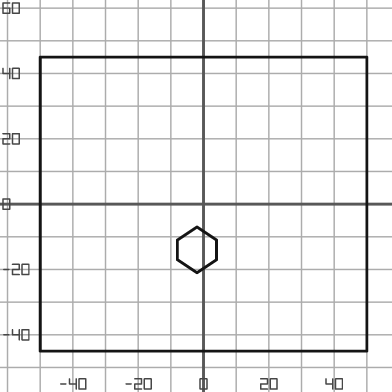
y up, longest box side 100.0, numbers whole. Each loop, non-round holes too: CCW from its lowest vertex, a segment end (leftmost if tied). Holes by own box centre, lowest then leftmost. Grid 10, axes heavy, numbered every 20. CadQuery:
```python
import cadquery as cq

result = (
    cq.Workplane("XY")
    .moveTo(-50.0, -45.0)
    .lineTo(50.0, -45.0)
    .lineTo(50.0, 45.0)
    .lineTo(-50.0, 45.0)
    .close()
    .moveTo(-2.0, -21.0)
    .lineTo(4.0, -17.0)
    .lineTo(4.0, -11.0)
    .lineTo(-2.0, -7.0)
    .lineTo(-8.0, -11.0)
    .lineTo(-8.0, -17.0)
    .close()
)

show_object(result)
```